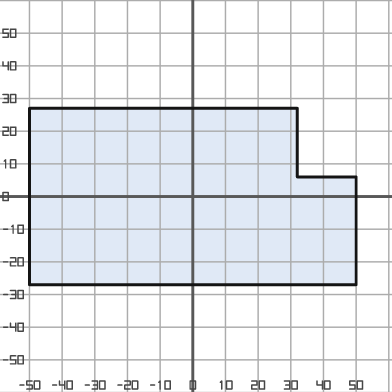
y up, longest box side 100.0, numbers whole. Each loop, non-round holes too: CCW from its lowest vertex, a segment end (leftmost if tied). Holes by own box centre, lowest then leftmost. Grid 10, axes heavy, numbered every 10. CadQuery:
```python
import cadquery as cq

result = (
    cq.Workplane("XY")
    .moveTo(-50.0, -27.0)
    .lineTo(50.0, -27.0)
    .lineTo(50.0, 6.0)
    .lineTo(32.0, 6.0)
    .lineTo(32.0, 27.0)
    .lineTo(-50.0, 27.0)
    .close()
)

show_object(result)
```